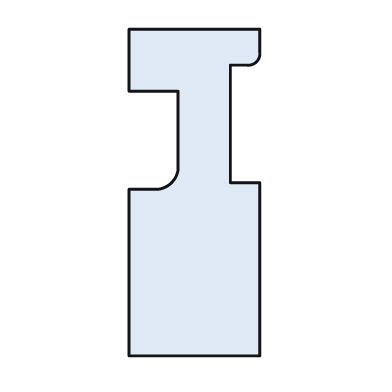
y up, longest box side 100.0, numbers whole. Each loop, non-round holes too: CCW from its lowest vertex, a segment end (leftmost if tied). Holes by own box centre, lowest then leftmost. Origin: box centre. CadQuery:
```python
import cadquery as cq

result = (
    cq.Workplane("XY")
    .moveTo(-20.0, -50.0)
    .lineTo(20.0, -50.0)
    .lineTo(20.0, 3.0)
    .lineTo(11.0, 3.0)
    .lineTo(11.0, 39.0)
    .lineTo(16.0, 39.0)
    .threePointArc((19.0, 40.0), (20.0, 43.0))
    .lineTo(20.0, 50.0)
    .lineTo(-20.0, 50.0)
    .lineTo(-20.0, 31.0)
    .lineTo(-5.0, 31.0)
    .lineTo(-5.0, 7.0)
    .threePointArc((-7.0, 3.0), (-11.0, 1.0))
    .lineTo(-20.0, 1.0)
    .close()
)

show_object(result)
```